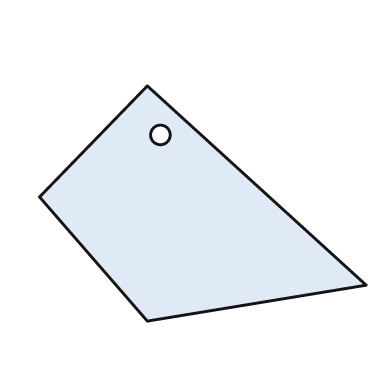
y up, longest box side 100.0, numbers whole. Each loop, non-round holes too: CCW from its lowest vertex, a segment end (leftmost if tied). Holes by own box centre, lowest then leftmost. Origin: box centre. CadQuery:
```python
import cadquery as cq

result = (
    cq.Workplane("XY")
    .moveTo(-17.0, -36.0)
    .lineTo(50.0, -25.0)
    .lineTo(-17.0, 36.0)
    .lineTo(-50.0, 2.0)
    .close()
    .moveTo(-13.0, 21.0)
    .circle(3.0)
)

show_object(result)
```